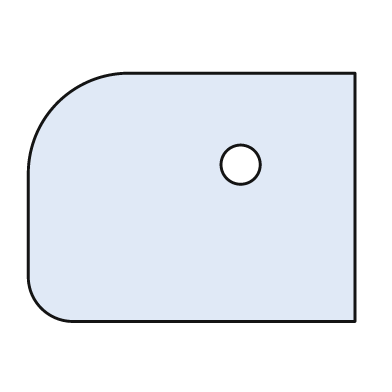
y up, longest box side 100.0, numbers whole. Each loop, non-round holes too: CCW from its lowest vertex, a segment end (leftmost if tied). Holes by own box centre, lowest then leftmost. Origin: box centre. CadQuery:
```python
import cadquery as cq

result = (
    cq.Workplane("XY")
    .moveTo(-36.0, -38.0)
    .lineTo(50.0, -38.0)
    .lineTo(50.0, 38.0)
    .lineTo(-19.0, 38.0)
    .threePointArc((-41.0, 29.0), (-50.0, 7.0))
    .lineTo(-50.0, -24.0)
    .threePointArc((-46.0, -34.0), (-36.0, -38.0))
    .close()
    .moveTo(15.0, 10.0)
    .circle(6.0)
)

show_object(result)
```